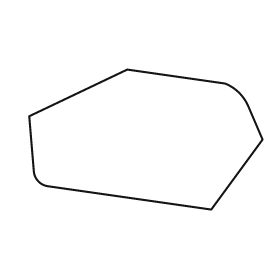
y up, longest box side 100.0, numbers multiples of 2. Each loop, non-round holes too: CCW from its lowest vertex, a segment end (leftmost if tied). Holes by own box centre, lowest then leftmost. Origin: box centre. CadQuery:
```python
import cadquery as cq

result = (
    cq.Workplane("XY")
    .moveTo(28.0, -30.0)
    .lineTo(50.0, 0.0)
    .lineTo(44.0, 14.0)
    .threePointArc((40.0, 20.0), (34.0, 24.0))
    .lineTo(-8.0, 30.0)
    .lineTo(-50.0, 10.0)
    .lineTo(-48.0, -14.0)
    .threePointArc((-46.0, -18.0), (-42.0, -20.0))
    .close()
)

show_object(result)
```